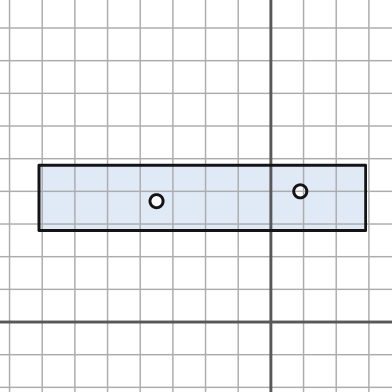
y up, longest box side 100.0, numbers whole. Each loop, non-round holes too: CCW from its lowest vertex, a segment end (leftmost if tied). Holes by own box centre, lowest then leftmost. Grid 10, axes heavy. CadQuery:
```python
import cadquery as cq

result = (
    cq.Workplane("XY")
    .moveTo(-71.0, 28.0)
    .lineTo(29.0, 28.0)
    .lineTo(29.0, 48.0)
    .lineTo(-71.0, 48.0)
    .close()
    .moveTo(-35.0, 37.0)
    .circle(2.0)
    .moveTo(9.0, 40.0)
    .circle(2.0)
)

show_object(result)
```